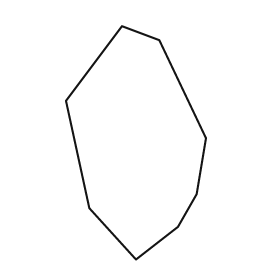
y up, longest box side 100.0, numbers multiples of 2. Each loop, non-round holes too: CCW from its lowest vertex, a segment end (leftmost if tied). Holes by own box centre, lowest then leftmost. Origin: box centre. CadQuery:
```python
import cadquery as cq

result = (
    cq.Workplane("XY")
    .moveTo(0.0, -50.0)
    .lineTo(18.0, -36.0)
    .lineTo(26.0, -22.0)
    .lineTo(30.0, 2.0)
    .lineTo(10.0, 44.0)
    .lineTo(-6.0, 50.0)
    .lineTo(-30.0, 18.0)
    .lineTo(-20.0, -28.0)
    .close()
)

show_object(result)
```